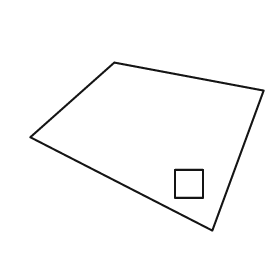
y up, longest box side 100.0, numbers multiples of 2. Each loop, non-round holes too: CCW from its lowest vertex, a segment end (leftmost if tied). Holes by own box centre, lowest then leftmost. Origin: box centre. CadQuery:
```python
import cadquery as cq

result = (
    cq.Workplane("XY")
    .moveTo(28.0, -36.0)
    .lineTo(50.0, 24.0)
    .lineTo(-14.0, 36.0)
    .lineTo(-50.0, 4.0)
    .close()
    .moveTo(12.0, -22.0)
    .lineTo(24.0, -22.0)
    .lineTo(24.0, -10.0)
    .lineTo(12.0, -10.0)
    .close()
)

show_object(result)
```